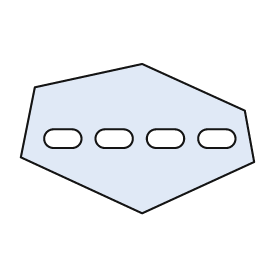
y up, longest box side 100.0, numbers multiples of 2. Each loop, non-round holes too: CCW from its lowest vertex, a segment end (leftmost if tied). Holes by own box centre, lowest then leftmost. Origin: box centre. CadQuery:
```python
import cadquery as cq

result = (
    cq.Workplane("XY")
    .moveTo(2.0, -32.0)
    .lineTo(50.0, -10.0)
    .lineTo(46.0, 12.0)
    .lineTo(2.0, 32.0)
    .lineTo(-44.0, 22.0)
    .lineTo(-50.0, -8.0)
    .close()
    .moveTo(-36.0, -4.0)
    .lineTo(-28.0, -4.0)
    .threePointArc((-24.0, 0.0), (-28.0, 4.0))
    .lineTo(-36.0, 4.0)
    .threePointArc((-40.0, 0.0), (-36.0, -4.0))
    .close()
    .moveTo(-14.0, -4.0)
    .lineTo(-6.0, -4.0)
    .threePointArc((-2.0, 0.0), (-6.0, 4.0))
    .lineTo(-14.0, 4.0)
    .threePointArc((-18.0, 0.0), (-14.0, -4.0))
    .close()
    .moveTo(8.0, -4.0)
    .lineTo(16.0, -4.0)
    .threePointArc((20.0, 0.0), (16.0, 4.0))
    .lineTo(8.0, 4.0)
    .threePointArc((4.0, 0.0), (8.0, -4.0))
    .close()
    .moveTo(30.0, -4.0)
    .lineTo(38.0, -4.0)
    .threePointArc((42.0, 0.0), (38.0, 4.0))
    .lineTo(30.0, 4.0)
    .threePointArc((26.0, 0.0), (30.0, -4.0))
    .close()
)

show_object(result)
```